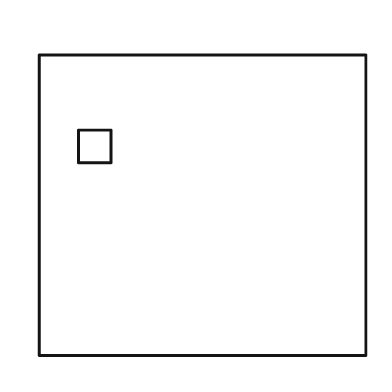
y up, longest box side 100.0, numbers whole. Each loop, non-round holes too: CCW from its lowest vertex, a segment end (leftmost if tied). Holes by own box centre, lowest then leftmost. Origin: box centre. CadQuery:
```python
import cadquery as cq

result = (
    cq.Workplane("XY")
    .moveTo(-50.0, -46.0)
    .lineTo(50.0, -46.0)
    .lineTo(50.0, 46.0)
    .lineTo(-50.0, 46.0)
    .close()
    .moveTo(-38.0, 13.0)
    .lineTo(-28.0, 13.0)
    .lineTo(-28.0, 23.0)
    .lineTo(-38.0, 23.0)
    .close()
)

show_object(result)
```